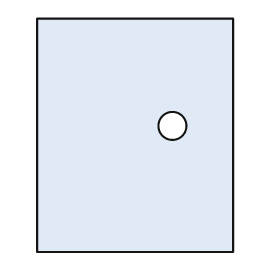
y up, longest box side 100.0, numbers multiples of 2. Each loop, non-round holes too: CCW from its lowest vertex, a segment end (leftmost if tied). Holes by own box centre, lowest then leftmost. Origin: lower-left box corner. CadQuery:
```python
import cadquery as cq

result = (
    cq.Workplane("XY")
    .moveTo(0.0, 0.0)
    .lineTo(84.0, 0.0)
    .lineTo(84.0, 100.0)
    .lineTo(0.0, 100.0)
    .close()
    .moveTo(58.0, 54.0)
    .circle(6.0)
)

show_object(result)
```